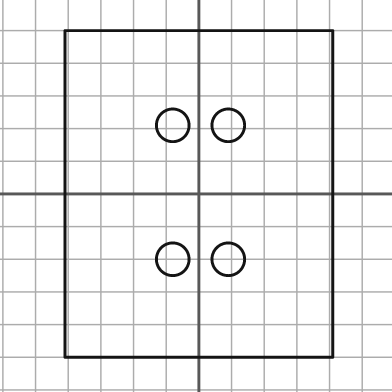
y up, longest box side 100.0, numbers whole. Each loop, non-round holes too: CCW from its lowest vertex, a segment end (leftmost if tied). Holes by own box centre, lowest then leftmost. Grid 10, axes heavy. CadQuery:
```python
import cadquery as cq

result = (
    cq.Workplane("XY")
    .moveTo(-41.0, -50.0)
    .lineTo(41.0, -50.0)
    .lineTo(41.0, 50.0)
    .lineTo(-41.0, 50.0)
    .close()
    .moveTo(-8.0, -20.0)
    .circle(5.0)
    .moveTo(9.0, -20.0)
    .circle(5.0)
    .moveTo(-8.0, 21.0)
    .circle(5.0)
    .moveTo(9.0, 21.0)
    .circle(5.0)
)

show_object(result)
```